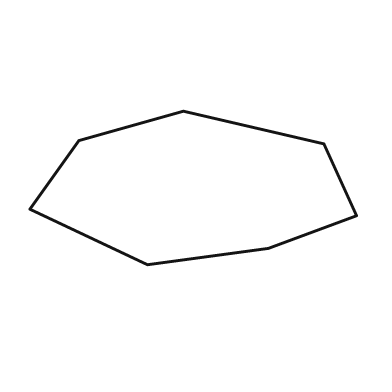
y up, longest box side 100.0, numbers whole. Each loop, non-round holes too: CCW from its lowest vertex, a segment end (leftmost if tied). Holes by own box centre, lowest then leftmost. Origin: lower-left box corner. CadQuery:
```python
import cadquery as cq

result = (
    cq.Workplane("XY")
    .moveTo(36.0, 0.0)
    .lineTo(73.0, 5.0)
    .lineTo(100.0, 15.0)
    .lineTo(90.0, 37.0)
    .lineTo(47.0, 47.0)
    .lineTo(15.0, 38.0)
    .lineTo(0.0, 17.0)
    .close()
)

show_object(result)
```